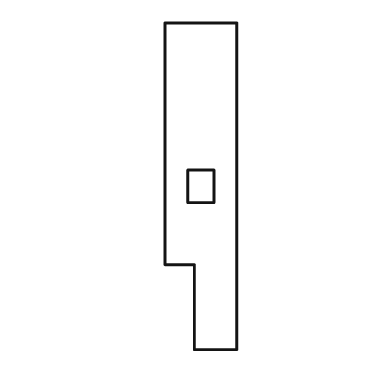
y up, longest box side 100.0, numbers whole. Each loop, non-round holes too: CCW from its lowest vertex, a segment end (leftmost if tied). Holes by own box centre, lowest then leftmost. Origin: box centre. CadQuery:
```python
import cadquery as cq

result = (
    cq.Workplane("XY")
    .moveTo(-2.0, -50.0)
    .lineTo(11.0, -50.0)
    .lineTo(11.0, 50.0)
    .lineTo(-11.0, 50.0)
    .lineTo(-11.0, -24.0)
    .lineTo(-2.0, -24.0)
    .close()
    .moveTo(-4.0, -5.0)
    .lineTo(4.0, -5.0)
    .lineTo(4.0, 5.0)
    .lineTo(-4.0, 5.0)
    .close()
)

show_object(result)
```